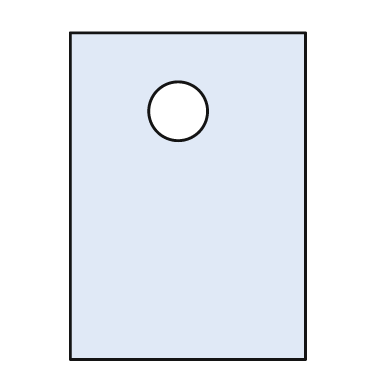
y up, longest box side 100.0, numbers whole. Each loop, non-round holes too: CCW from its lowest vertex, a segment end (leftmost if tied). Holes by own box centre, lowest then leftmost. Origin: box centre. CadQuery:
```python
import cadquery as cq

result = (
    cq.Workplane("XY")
    .moveTo(-36.0, -50.0)
    .lineTo(36.0, -50.0)
    .lineTo(36.0, 50.0)
    .lineTo(-36.0, 50.0)
    .close()
    .moveTo(-3.0, 26.0)
    .circle(9.0)
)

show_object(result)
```